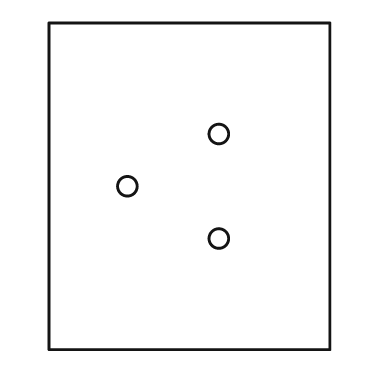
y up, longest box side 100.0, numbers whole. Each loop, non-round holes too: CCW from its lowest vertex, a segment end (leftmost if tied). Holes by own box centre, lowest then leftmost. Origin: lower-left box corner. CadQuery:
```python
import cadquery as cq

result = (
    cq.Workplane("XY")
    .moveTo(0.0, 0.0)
    .lineTo(86.0, 0.0)
    .lineTo(86.0, 100.0)
    .lineTo(0.0, 100.0)
    .close()
    .moveTo(52.0, 34.0)
    .circle(3.0)
    .moveTo(24.0, 50.0)
    .circle(3.0)
    .moveTo(52.0, 66.0)
    .circle(3.0)
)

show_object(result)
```